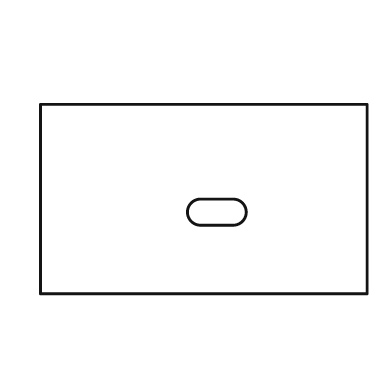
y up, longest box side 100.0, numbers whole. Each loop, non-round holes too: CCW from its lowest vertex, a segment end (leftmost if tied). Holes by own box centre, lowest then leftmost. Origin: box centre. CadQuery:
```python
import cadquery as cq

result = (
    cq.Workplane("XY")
    .moveTo(-50.0, -29.0)
    .lineTo(50.0, -29.0)
    .lineTo(50.0, 29.0)
    .lineTo(-50.0, 29.0)
    .close()
    .moveTo(-1.0, -8.0)
    .lineTo(9.0, -8.0)
    .threePointArc((13.0, -4.0), (9.0, 0.0))
    .lineTo(-1.0, 0.0)
    .threePointArc((-5.0, -4.0), (-1.0, -8.0))
    .close()
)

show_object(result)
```